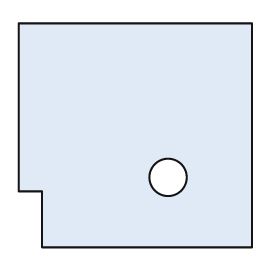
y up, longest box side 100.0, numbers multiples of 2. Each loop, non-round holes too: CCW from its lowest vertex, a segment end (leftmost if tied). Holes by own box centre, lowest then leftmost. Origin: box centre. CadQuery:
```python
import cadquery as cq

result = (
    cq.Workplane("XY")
    .moveTo(-40.0, -48.0)
    .lineTo(50.0, -48.0)
    .lineTo(50.0, 48.0)
    .lineTo(-50.0, 48.0)
    .lineTo(-50.0, -24.0)
    .lineTo(-40.0, -24.0)
    .close()
    .moveTo(14.0, -18.0)
    .circle(8.0)
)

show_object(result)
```